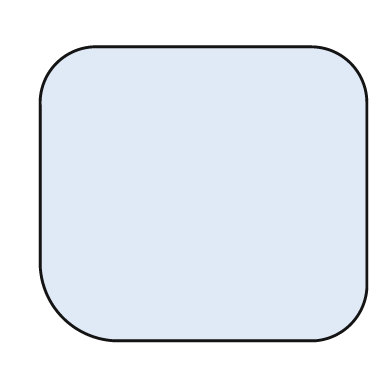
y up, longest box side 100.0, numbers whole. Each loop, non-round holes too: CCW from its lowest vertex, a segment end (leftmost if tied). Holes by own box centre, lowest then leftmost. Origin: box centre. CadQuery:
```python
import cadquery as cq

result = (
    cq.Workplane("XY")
    .moveTo(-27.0, -45.0)
    .lineTo(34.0, -45.0)
    .threePointArc((45.0, -40.0), (50.0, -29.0))
    .lineTo(50.0, 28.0)
    .threePointArc((45.0, 40.0), (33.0, 45.0))
    .lineTo(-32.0, 45.0)
    .threePointArc((-45.0, 40.0), (-50.0, 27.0))
    .lineTo(-50.0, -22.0)
    .threePointArc((-43.0, -38.0), (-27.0, -45.0))
    .close()
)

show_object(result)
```